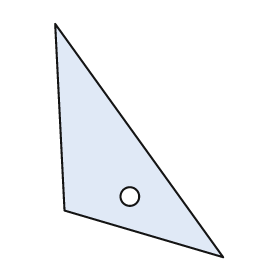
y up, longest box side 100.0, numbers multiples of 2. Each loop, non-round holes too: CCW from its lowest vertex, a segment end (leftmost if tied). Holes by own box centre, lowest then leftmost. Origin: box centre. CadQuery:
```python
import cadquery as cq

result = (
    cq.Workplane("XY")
    .moveTo(36.0, -50.0)
    .lineTo(-36.0, 50.0)
    .lineTo(-32.0, -30.0)
    .close()
    .moveTo(-4.0, -24.0)
    .circle(4.0)
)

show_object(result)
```